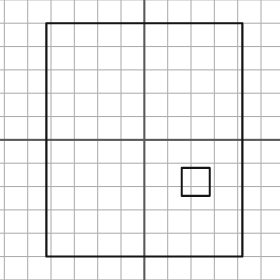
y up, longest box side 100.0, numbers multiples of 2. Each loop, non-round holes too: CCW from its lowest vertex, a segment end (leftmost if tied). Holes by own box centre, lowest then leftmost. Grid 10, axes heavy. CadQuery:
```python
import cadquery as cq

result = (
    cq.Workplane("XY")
    .moveTo(-42.0, -50.0)
    .lineTo(42.0, -50.0)
    .lineTo(42.0, 50.0)
    .lineTo(-42.0, 50.0)
    .close()
    .moveTo(16.0, -24.0)
    .lineTo(28.0, -24.0)
    .lineTo(28.0, -12.0)
    .lineTo(16.0, -12.0)
    .close()
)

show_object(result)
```